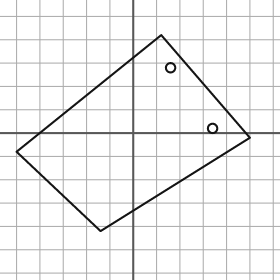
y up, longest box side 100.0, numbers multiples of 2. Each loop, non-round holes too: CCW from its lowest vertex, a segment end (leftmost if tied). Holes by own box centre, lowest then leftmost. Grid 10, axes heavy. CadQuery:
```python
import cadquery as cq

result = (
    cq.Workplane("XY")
    .moveTo(-14.0, -42.0)
    .lineTo(50.0, -2.0)
    .lineTo(12.0, 42.0)
    .lineTo(-50.0, -8.0)
    .close()
    .moveTo(34.0, 2.0)
    .circle(2.0)
    .moveTo(16.0, 28.0)
    .circle(2.0)
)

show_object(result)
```